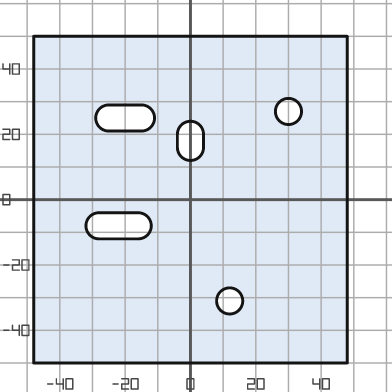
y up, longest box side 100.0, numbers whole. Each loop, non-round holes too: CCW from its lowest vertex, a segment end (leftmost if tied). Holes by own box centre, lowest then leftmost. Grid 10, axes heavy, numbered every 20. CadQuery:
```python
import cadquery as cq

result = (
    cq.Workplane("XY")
    .moveTo(-48.0, -50.0)
    .lineTo(48.0, -50.0)
    .lineTo(48.0, 50.0)
    .lineTo(-48.0, 50.0)
    .close()
    .moveTo(12.0, -31.0)
    .circle(4.0)
    .moveTo(-28.0, -12.0)
    .lineTo(-16.0, -12.0)
    .threePointArc((-12.0, -8.0), (-16.0, -4.0))
    .lineTo(-28.0, -4.0)
    .threePointArc((-32.0, -8.0), (-28.0, -12.0))
    .close()
    .moveTo(-4.0, 16.0)
    .threePointArc((0.0, 12.0), (4.0, 16.0))
    .lineTo(4.0, 20.0)
    .threePointArc((0.0, 24.0), (-4.0, 20.0))
    .close()
    .moveTo(-25.0, 21.0)
    .lineTo(-15.0, 21.0)
    .threePointArc((-11.0, 25.0), (-15.0, 29.0))
    .lineTo(-25.0, 29.0)
    .threePointArc((-29.0, 25.0), (-25.0, 21.0))
    .close()
    .moveTo(30.0, 27.0)
    .circle(4.0)
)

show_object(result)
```